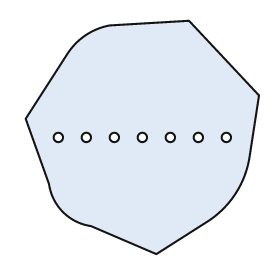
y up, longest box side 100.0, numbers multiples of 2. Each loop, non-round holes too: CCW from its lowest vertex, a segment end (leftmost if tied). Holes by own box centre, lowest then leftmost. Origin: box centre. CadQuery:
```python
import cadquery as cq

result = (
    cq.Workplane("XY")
    .moveTo(6.0, -50.0)
    .lineTo(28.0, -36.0)
    .threePointArc((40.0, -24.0), (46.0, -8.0))
    .lineTo(50.0, 18.0)
    .lineTo(20.0, 50.0)
    .lineTo(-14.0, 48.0)
    .threePointArc((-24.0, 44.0), (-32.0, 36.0))
    .lineTo(-50.0, 8.0)
    .lineTo(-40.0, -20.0)
    .threePointArc((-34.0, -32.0), (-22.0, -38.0))
    .close()
    .moveTo(-36.0, 0.0)
    .circle(2.0)
    .moveTo(-24.0, 0.0)
    .circle(2.0)
    .moveTo(-12.0, 0.0)
    .circle(2.0)
    .moveTo(0.0, 0.0)
    .circle(2.0)
    .moveTo(12.0, 0.0)
    .circle(2.0)
    .moveTo(24.0, 0.0)
    .circle(2.0)
    .moveTo(36.0, 0.0)
    .circle(2.0)
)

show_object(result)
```